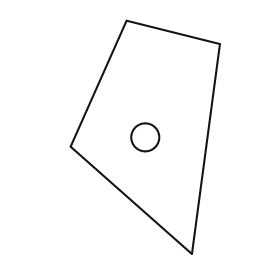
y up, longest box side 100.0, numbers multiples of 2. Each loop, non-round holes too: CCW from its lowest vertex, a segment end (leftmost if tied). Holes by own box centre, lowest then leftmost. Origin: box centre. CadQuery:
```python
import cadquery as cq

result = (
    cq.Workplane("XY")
    .moveTo(20.0, -50.0)
    .lineTo(32.0, 40.0)
    .lineTo(-8.0, 50.0)
    .lineTo(-32.0, -4.0)
    .close()
    .moveTo(0.0, 0.0)
    .circle(6.0)
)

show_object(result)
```